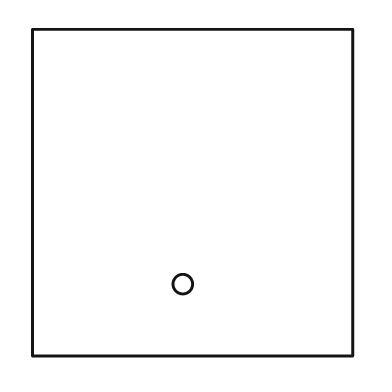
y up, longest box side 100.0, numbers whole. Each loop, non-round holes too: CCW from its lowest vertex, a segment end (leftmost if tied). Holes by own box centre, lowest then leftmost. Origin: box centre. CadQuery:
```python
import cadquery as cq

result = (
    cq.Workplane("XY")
    .moveTo(-49.0, -50.0)
    .lineTo(49.0, -50.0)
    .lineTo(49.0, 50.0)
    .lineTo(-49.0, 50.0)
    .close()
    .moveTo(-3.0, -28.0)
    .circle(3.0)
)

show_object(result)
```